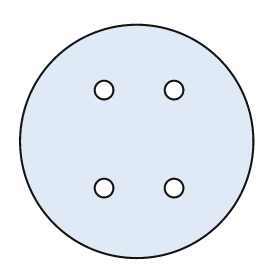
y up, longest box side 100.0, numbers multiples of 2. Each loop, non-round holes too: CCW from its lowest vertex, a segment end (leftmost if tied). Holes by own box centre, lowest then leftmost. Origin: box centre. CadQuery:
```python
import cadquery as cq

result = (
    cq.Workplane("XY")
    .moveTo(0.0, 0.0)
    .circle(50.0)
    .moveTo(-14.0, -20.0)
    .circle(4.0)
    .moveTo(16.0, -20.0)
    .circle(4.0)
    .moveTo(-14.0, 22.0)
    .circle(4.0)
    .moveTo(16.0, 22.0)
    .circle(4.0)
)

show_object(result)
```